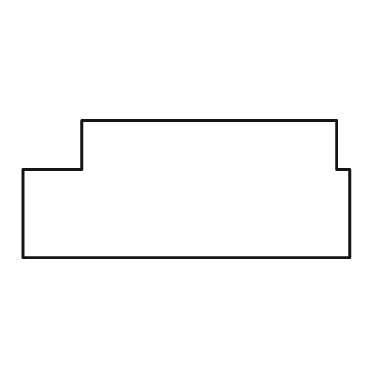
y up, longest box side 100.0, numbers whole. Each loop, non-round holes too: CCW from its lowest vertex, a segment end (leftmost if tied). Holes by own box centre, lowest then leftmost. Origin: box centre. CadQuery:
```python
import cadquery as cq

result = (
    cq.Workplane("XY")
    .moveTo(-50.0, -21.0)
    .lineTo(50.0, -21.0)
    .lineTo(50.0, 6.0)
    .lineTo(46.0, 6.0)
    .lineTo(46.0, 21.0)
    .lineTo(-32.0, 21.0)
    .lineTo(-32.0, 6.0)
    .lineTo(-50.0, 6.0)
    .close()
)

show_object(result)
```